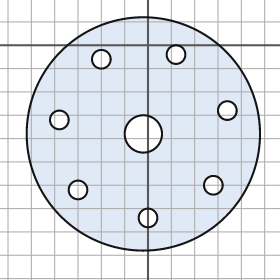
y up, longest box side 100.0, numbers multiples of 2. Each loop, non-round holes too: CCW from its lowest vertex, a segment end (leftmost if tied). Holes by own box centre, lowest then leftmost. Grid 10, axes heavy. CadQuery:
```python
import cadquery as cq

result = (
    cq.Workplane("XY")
    .moveTo(-2.0, -38.0)
    .circle(50.0)
    .moveTo(0.0, -74.0)
    .circle(4.0)
    .moveTo(-30.0, -62.0)
    .circle(4.0)
    .moveTo(28.0, -60.0)
    .circle(4.0)
    .moveTo(-2.0, -38.0)
    .circle(8.0)
    .moveTo(-38.0, -32.0)
    .circle(4.0)
    .moveTo(34.0, -28.0)
    .circle(4.0)
    .moveTo(-20.0, -6.0)
    .circle(4.0)
    .moveTo(12.0, -4.0)
    .circle(4.0)
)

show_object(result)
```